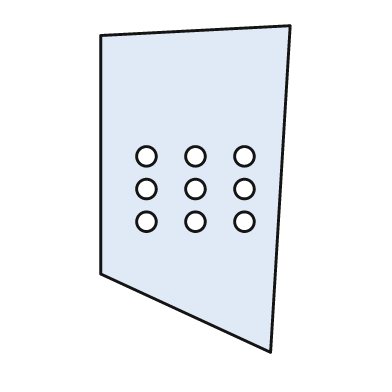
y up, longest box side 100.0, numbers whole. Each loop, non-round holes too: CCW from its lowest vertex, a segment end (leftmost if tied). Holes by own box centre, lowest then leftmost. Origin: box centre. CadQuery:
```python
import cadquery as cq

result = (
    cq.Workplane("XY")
    .moveTo(23.0, -50.0)
    .lineTo(29.0, 50.0)
    .lineTo(-29.0, 47.0)
    .lineTo(-29.0, -26.0)
    .close()
    .moveTo(-15.0, -10.0)
    .circle(3.0)
    .moveTo(0.0, -10.0)
    .circle(3.0)
    .moveTo(15.0, -10.0)
    .circle(3.0)
    .moveTo(-15.0, 0.0)
    .circle(3.0)
    .moveTo(0.0, 0.0)
    .circle(3.0)
    .moveTo(15.0, 0.0)
    .circle(3.0)
    .moveTo(-15.0, 10.0)
    .circle(3.0)
    .moveTo(0.0, 10.0)
    .circle(3.0)
    .moveTo(15.0, 10.0)
    .circle(3.0)
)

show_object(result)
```